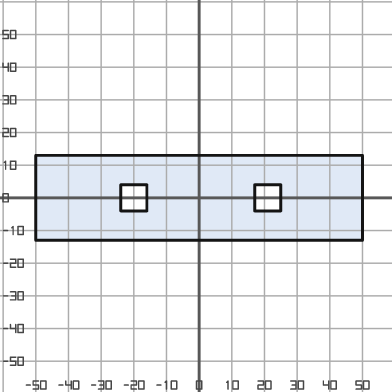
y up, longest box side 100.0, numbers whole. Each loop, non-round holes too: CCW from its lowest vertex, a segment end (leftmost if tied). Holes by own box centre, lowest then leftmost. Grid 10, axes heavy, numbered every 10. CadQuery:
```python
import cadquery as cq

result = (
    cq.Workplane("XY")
    .moveTo(-50.0, -13.0)
    .lineTo(50.0, -13.0)
    .lineTo(50.0, 13.0)
    .lineTo(-50.0, 13.0)
    .close()
    .moveTo(-24.0, -4.0)
    .lineTo(-16.0, -4.0)
    .lineTo(-16.0, 4.0)
    .lineTo(-24.0, 4.0)
    .close()
    .moveTo(17.0, -4.0)
    .lineTo(25.0, -4.0)
    .lineTo(25.0, 4.0)
    .lineTo(17.0, 4.0)
    .close()
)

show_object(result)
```